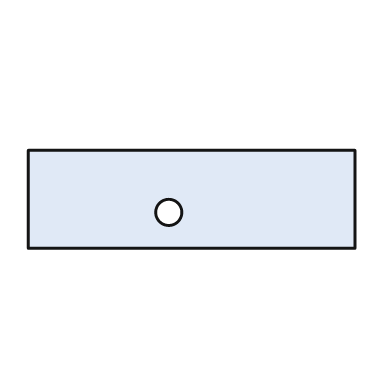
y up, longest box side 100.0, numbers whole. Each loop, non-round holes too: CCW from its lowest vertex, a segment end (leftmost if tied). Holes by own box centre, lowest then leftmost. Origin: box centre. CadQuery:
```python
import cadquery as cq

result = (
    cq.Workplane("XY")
    .moveTo(-50.0, -15.0)
    .lineTo(50.0, -15.0)
    .lineTo(50.0, 15.0)
    .lineTo(-50.0, 15.0)
    .close()
    .moveTo(-7.0, -4.0)
    .circle(4.0)
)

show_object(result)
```